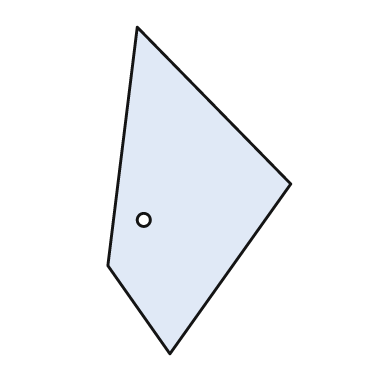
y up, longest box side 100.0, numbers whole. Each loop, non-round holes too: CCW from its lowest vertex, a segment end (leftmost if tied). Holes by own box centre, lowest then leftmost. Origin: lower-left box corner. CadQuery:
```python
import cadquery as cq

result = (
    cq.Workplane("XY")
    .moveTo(19.0, 0.0)
    .lineTo(56.0, 52.0)
    .lineTo(9.0, 100.0)
    .lineTo(0.0, 27.0)
    .close()
    .moveTo(11.0, 41.0)
    .circle(2.0)
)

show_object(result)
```